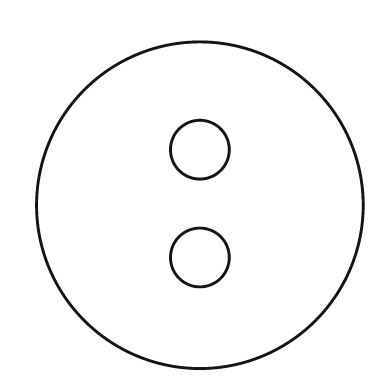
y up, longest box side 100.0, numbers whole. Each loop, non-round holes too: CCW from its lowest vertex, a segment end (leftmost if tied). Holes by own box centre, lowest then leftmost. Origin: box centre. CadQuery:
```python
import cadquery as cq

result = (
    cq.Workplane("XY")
    .moveTo(0.0, 0.0)
    .circle(50.0)
    .moveTo(0.0, -16.0)
    .circle(9.0)
    .moveTo(0.0, 17.0)
    .circle(9.0)
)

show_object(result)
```